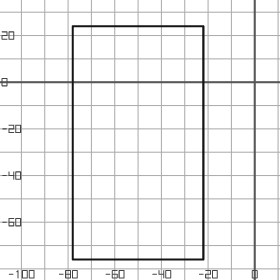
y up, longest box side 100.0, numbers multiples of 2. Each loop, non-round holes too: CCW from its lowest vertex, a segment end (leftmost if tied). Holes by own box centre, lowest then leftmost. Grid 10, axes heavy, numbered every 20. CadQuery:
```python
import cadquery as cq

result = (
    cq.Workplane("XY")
    .moveTo(-78.0, -76.0)
    .lineTo(-22.0, -76.0)
    .lineTo(-22.0, 24.0)
    .lineTo(-78.0, 24.0)
    .close()
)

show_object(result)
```